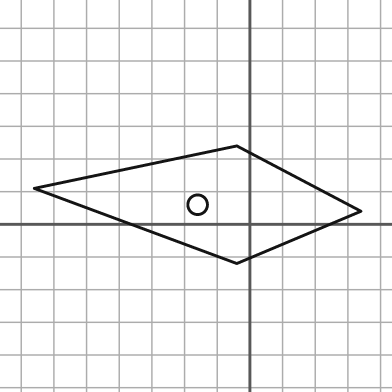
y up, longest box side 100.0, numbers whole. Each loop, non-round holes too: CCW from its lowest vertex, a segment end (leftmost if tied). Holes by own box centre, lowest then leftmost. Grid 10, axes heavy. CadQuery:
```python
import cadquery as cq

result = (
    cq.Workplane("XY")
    .moveTo(-4.0, -12.0)
    .lineTo(34.0, 4.0)
    .lineTo(-4.0, 24.0)
    .lineTo(-66.0, 11.0)
    .close()
    .moveTo(-16.0, 6.0)
    .circle(3.0)
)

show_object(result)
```